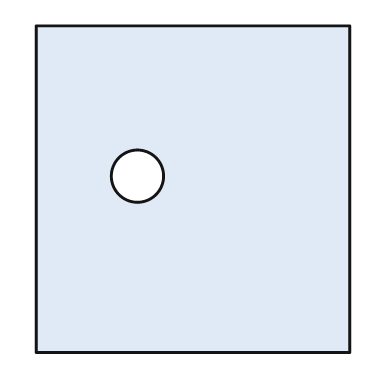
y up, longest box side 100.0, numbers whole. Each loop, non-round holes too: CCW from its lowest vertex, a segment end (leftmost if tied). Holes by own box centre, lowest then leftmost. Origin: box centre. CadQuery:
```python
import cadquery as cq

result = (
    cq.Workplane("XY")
    .moveTo(-48.0, -50.0)
    .lineTo(48.0, -50.0)
    .lineTo(48.0, 50.0)
    .lineTo(-48.0, 50.0)
    .close()
    .moveTo(-17.0, 4.0)
    .circle(8.0)
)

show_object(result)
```